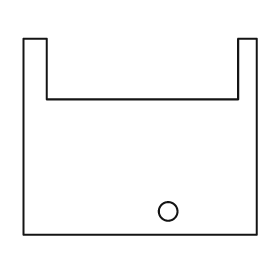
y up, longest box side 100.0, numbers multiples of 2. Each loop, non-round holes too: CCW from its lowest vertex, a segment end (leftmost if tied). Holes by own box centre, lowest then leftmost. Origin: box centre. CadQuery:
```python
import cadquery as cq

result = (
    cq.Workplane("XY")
    .moveTo(-50.0, -42.0)
    .lineTo(50.0, -42.0)
    .lineTo(50.0, 42.0)
    .lineTo(42.0, 42.0)
    .lineTo(42.0, 16.0)
    .lineTo(-40.0, 16.0)
    .lineTo(-40.0, 42.0)
    .lineTo(-50.0, 42.0)
    .close()
    .moveTo(12.0, -32.0)
    .circle(4.0)
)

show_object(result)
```